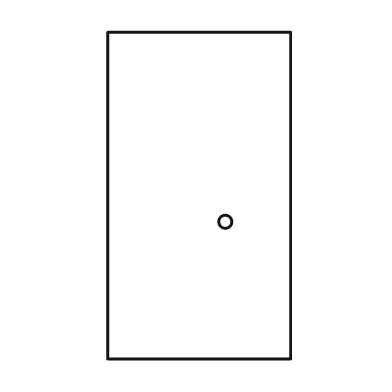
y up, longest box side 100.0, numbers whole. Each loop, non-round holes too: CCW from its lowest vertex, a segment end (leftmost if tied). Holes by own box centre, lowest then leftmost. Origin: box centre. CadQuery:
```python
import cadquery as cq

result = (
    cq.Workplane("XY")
    .moveTo(-28.0, -50.0)
    .lineTo(28.0, -50.0)
    .lineTo(28.0, 50.0)
    .lineTo(-28.0, 50.0)
    .close()
    .moveTo(8.0, -8.0)
    .circle(2.0)
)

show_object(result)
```